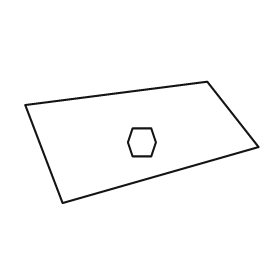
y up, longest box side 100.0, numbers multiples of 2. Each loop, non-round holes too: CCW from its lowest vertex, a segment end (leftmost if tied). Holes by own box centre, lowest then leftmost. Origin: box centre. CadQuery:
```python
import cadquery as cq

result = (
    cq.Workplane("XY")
    .moveTo(-34.0, -26.0)
    .lineTo(50.0, -2.0)
    .lineTo(28.0, 26.0)
    .lineTo(-50.0, 16.0)
    .close()
    .moveTo(-4.0, -6.0)
    .lineTo(4.0, -6.0)
    .lineTo(6.0, 0.0)
    .lineTo(4.0, 6.0)
    .lineTo(-4.0, 6.0)
    .lineTo(-6.0, 0.0)
    .close()
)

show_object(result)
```